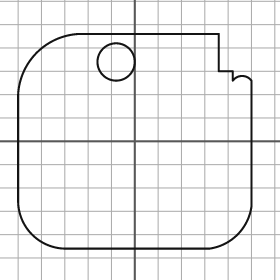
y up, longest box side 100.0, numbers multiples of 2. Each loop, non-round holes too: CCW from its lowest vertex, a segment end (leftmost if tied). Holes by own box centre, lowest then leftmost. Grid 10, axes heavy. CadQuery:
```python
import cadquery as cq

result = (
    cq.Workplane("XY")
    .moveTo(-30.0, -46.0)
    .lineTo(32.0, -46.0)
    .threePointArc((44.0, -40.0), (50.0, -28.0))
    .lineTo(50.0, 26.0)
    .threePointArc((46.0, 28.0), (42.0, 26.0))
    .lineTo(42.0, 30.0)
    .lineTo(36.0, 30.0)
    .lineTo(36.0, 46.0)
    .lineTo(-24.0, 46.0)
    .threePointArc((-42.0, 38.0), (-50.0, 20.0))
    .lineTo(-50.0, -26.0)
    .threePointArc((-44.0, -40.0), (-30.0, -46.0))
    .close()
    .moveTo(-8.0, 34.0)
    .circle(8.0)
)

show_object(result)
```